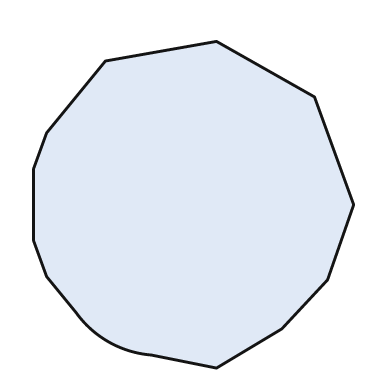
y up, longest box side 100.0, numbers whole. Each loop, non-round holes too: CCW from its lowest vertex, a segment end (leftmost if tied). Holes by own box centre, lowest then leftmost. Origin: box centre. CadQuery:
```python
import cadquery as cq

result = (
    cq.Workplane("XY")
    .moveTo(7.0, -50.0)
    .lineTo(27.0, -38.0)
    .lineTo(41.0, -23.0)
    .lineTo(49.0, 0.0)
    .lineTo(37.0, 33.0)
    .lineTo(7.0, 50.0)
    .lineTo(-27.0, 44.0)
    .lineTo(-45.0, 22.0)
    .lineTo(-49.0, 11.0)
    .lineTo(-49.0, -11.0)
    .lineTo(-45.0, -22.0)
    .lineTo(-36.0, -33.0)
    .threePointArc((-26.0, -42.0), (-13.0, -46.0))
    .close()
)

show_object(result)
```